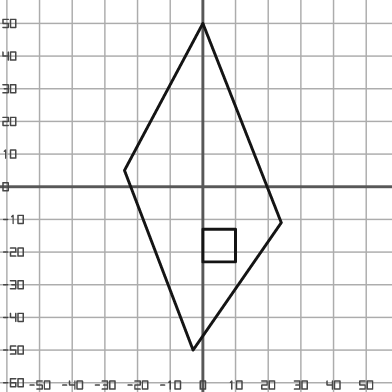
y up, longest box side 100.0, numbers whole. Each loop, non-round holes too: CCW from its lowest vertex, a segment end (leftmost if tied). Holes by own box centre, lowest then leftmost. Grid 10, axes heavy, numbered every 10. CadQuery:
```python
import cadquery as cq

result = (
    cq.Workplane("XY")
    .moveTo(-3.0, -50.0)
    .lineTo(24.0, -11.0)
    .lineTo(0.0, 50.0)
    .lineTo(-24.0, 5.0)
    .close()
    .moveTo(0.0, -23.0)
    .lineTo(10.0, -23.0)
    .lineTo(10.0, -13.0)
    .lineTo(0.0, -13.0)
    .close()
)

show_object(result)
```